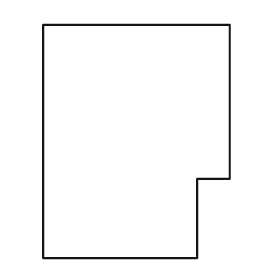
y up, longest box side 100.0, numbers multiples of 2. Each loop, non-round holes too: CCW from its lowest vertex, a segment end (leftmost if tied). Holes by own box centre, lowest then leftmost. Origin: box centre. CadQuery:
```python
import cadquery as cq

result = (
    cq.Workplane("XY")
    .moveTo(-40.0, -50.0)
    .lineTo(26.0, -50.0)
    .lineTo(26.0, -16.0)
    .lineTo(40.0, -16.0)
    .lineTo(40.0, 50.0)
    .lineTo(-40.0, 50.0)
    .close()
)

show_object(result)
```